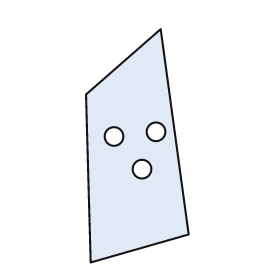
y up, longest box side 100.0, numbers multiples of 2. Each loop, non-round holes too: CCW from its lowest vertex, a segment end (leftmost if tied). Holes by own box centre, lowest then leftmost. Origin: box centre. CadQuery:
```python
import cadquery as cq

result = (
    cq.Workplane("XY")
    .moveTo(-20.0, -50.0)
    .lineTo(22.0, -38.0)
    .lineTo(10.0, 50.0)
    .lineTo(-22.0, 22.0)
    .close()
    .moveTo(2.0, -10.0)
    .circle(4.0)
    .moveTo(-10.0, 4.0)
    .circle(4.0)
    .moveTo(8.0, 6.0)
    .circle(4.0)
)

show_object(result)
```